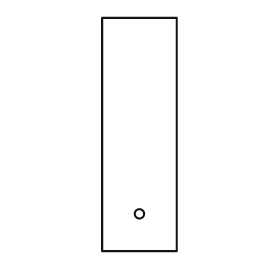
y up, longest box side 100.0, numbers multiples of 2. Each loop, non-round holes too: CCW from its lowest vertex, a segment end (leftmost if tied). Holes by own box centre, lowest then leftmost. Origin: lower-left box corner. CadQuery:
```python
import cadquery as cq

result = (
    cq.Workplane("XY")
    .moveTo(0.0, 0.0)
    .lineTo(32.0, 0.0)
    .lineTo(32.0, 100.0)
    .lineTo(0.0, 100.0)
    .close()
    .moveTo(16.0, 16.0)
    .circle(2.0)
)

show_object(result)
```